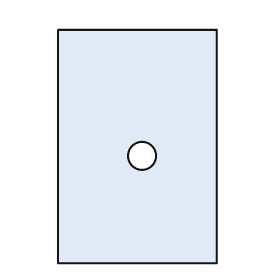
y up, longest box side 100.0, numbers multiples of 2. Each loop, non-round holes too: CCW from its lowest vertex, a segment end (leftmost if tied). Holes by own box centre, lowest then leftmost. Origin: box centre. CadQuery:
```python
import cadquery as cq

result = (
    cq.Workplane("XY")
    .moveTo(-34.0, -50.0)
    .lineTo(34.0, -50.0)
    .lineTo(34.0, 50.0)
    .lineTo(-34.0, 50.0)
    .close()
    .moveTo(2.0, -4.0)
    .circle(6.0)
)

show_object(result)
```